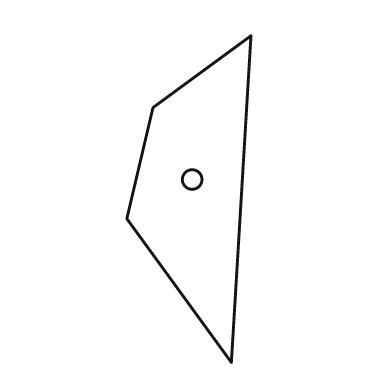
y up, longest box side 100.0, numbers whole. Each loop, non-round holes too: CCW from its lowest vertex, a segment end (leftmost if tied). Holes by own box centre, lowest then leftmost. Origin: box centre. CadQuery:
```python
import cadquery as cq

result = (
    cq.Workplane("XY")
    .moveTo(13.0, -50.0)
    .lineTo(19.0, 50.0)
    .lineTo(-11.0, 28.0)
    .lineTo(-19.0, -6.0)
    .close()
    .moveTo(1.0, 6.0)
    .circle(3.0)
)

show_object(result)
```